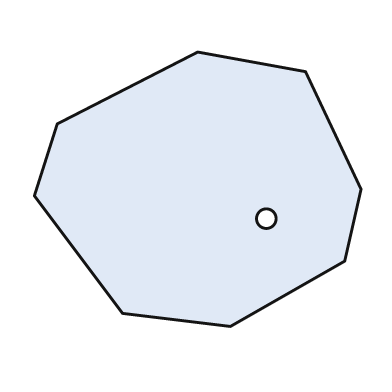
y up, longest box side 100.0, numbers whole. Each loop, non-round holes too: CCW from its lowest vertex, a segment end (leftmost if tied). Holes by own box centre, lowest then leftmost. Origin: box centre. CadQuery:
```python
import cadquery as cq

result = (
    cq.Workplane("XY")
    .moveTo(10.0, -42.0)
    .lineTo(45.0, -22.0)
    .lineTo(50.0, 0.0)
    .lineTo(33.0, 36.0)
    .lineTo(0.0, 42.0)
    .lineTo(-43.0, 20.0)
    .lineTo(-50.0, -2.0)
    .lineTo(-23.0, -38.0)
    .close()
    .moveTo(21.0, -9.0)
    .circle(3.0)
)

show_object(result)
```